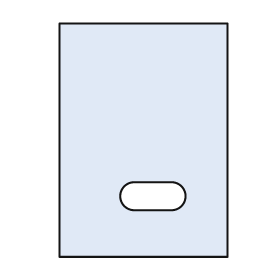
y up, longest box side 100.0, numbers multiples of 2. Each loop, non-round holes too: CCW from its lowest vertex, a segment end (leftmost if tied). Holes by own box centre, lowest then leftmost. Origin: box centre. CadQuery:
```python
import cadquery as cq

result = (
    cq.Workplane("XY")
    .moveTo(-36.0, -50.0)
    .lineTo(36.0, -50.0)
    .lineTo(36.0, 50.0)
    .lineTo(-36.0, 50.0)
    .close()
    .moveTo(-4.0, -30.0)
    .lineTo(12.0, -30.0)
    .threePointArc((18.0, -24.0), (12.0, -18.0))
    .lineTo(-4.0, -18.0)
    .threePointArc((-10.0, -24.0), (-4.0, -30.0))
    .close()
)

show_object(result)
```